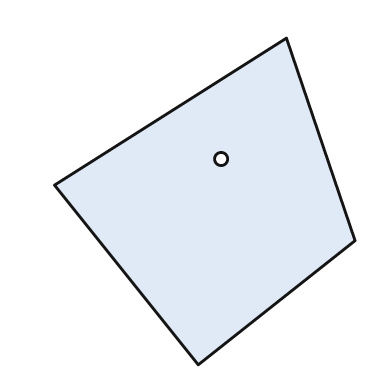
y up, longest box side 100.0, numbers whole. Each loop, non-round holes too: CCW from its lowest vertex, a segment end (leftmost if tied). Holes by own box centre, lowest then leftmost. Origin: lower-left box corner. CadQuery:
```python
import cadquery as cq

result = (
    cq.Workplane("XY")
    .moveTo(44.0, 0.0)
    .lineTo(92.0, 38.0)
    .lineTo(71.0, 100.0)
    .lineTo(0.0, 55.0)
    .close()
    .moveTo(51.0, 63.0)
    .circle(2.0)
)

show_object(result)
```